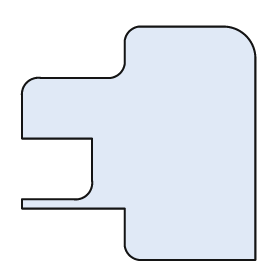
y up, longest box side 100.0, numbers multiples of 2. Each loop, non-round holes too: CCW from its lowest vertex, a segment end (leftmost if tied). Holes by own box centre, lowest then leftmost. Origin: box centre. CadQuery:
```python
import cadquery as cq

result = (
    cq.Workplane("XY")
    .moveTo(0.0, -50.0)
    .lineTo(50.0, -50.0)
    .lineTo(50.0, 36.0)
    .threePointArc((46.0, 46.0), (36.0, 50.0))
    .lineTo(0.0, 50.0)
    .threePointArc((-4.0, 48.0), (-6.0, 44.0))
    .lineTo(-6.0, 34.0)
    .threePointArc((-8.0, 30.0), (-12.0, 28.0))
    .lineTo(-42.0, 28.0)
    .threePointArc((-48.0, 26.0), (-50.0, 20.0))
    .lineTo(-50.0, 2.0)
    .lineTo(-20.0, 2.0)
    .lineTo(-20.0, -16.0)
    .threePointArc((-22.0, -22.0), (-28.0, -24.0))
    .lineTo(-50.0, -24.0)
    .lineTo(-50.0, -28.0)
    .lineTo(-6.0, -28.0)
    .lineTo(-6.0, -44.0)
    .threePointArc((-4.0, -48.0), (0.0, -50.0))
    .close()
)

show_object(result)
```